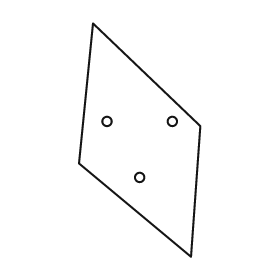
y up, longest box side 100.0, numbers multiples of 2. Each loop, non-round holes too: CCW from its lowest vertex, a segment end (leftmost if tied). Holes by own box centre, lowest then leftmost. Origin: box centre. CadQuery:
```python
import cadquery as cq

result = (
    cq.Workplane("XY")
    .moveTo(22.0, -50.0)
    .lineTo(26.0, 6.0)
    .lineTo(-20.0, 50.0)
    .lineTo(-26.0, -10.0)
    .close()
    .moveTo(0.0, -16.0)
    .circle(2.0)
    .moveTo(-14.0, 8.0)
    .circle(2.0)
    .moveTo(14.0, 8.0)
    .circle(2.0)
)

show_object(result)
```